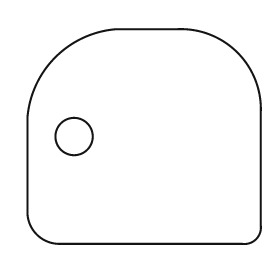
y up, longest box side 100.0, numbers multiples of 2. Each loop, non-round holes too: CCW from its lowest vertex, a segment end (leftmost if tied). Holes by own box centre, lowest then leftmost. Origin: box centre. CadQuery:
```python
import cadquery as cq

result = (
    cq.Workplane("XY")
    .moveTo(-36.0, -46.0)
    .lineTo(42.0, -46.0)
    .threePointArc((48.0, -44.0), (50.0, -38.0))
    .lineTo(50.0, 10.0)
    .threePointArc((40.0, 36.0), (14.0, 46.0))
    .lineTo(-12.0, 46.0)
    .threePointArc((-38.0, 34.0), (-50.0, 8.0))
    .lineTo(-50.0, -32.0)
    .threePointArc((-46.0, -42.0), (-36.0, -46.0))
    .close()
    .moveTo(-30.0, 0.0)
    .circle(8.0)
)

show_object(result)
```